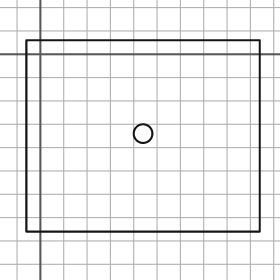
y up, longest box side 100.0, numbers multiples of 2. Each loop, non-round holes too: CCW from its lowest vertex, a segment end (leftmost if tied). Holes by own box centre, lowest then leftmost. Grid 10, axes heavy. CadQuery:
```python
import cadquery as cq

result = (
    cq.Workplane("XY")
    .moveTo(-6.0, -76.0)
    .lineTo(94.0, -76.0)
    .lineTo(94.0, 6.0)
    .lineTo(-6.0, 6.0)
    .close()
    .moveTo(44.0, -34.0)
    .circle(4.0)
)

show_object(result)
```